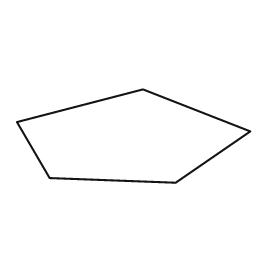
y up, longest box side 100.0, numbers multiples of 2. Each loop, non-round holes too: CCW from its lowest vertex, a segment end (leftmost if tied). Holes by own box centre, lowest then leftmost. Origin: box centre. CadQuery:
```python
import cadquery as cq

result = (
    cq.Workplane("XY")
    .moveTo(18.0, -20.0)
    .lineTo(50.0, 2.0)
    .lineTo(4.0, 20.0)
    .lineTo(-50.0, 6.0)
    .lineTo(-36.0, -18.0)
    .close()
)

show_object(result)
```